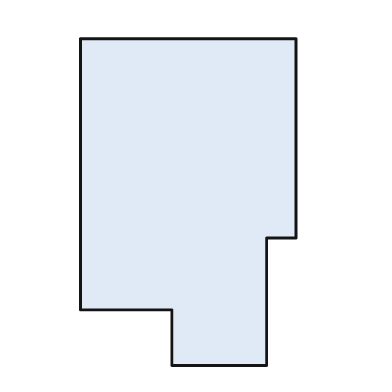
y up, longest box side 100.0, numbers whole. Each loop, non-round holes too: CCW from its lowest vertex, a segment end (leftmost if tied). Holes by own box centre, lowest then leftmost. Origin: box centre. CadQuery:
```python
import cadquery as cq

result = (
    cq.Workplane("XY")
    .moveTo(-5.0, -50.0)
    .lineTo(24.0, -50.0)
    .lineTo(24.0, -11.0)
    .lineTo(33.0, -11.0)
    .lineTo(33.0, 50.0)
    .lineTo(-33.0, 50.0)
    .lineTo(-33.0, -33.0)
    .lineTo(-5.0, -33.0)
    .close()
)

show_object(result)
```